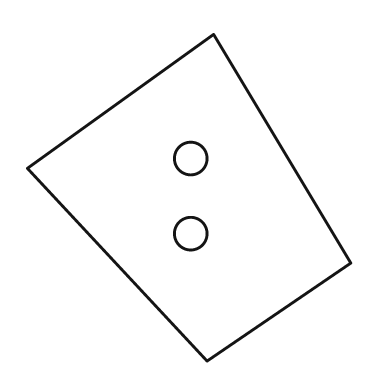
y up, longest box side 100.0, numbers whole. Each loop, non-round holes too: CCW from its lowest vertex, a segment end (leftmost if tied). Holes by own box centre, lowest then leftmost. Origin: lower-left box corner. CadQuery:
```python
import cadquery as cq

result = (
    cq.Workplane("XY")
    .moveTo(55.0, 0.0)
    .lineTo(99.0, 30.0)
    .lineTo(57.0, 100.0)
    .lineTo(0.0, 59.0)
    .close()
    .moveTo(50.0, 39.0)
    .circle(5.0)
    .moveTo(50.0, 62.0)
    .circle(5.0)
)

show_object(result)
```